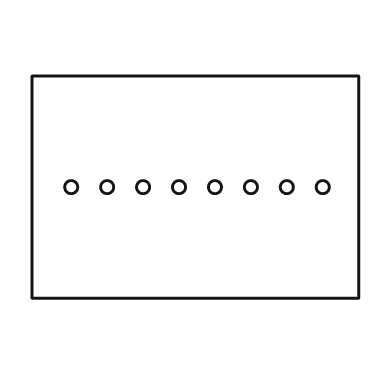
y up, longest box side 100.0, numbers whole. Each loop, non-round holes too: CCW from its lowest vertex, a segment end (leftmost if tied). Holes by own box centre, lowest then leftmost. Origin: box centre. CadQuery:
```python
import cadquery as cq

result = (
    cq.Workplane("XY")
    .moveTo(-50.0, -34.0)
    .lineTo(50.0, -34.0)
    .lineTo(50.0, 34.0)
    .lineTo(-50.0, 34.0)
    .close()
    .moveTo(-38.0, 0.0)
    .circle(2.0)
    .moveTo(-27.0, 0.0)
    .circle(2.0)
    .moveTo(-16.0, 0.0)
    .circle(2.0)
    .moveTo(-5.0, 0.0)
    .circle(2.0)
    .moveTo(6.0, 0.0)
    .circle(2.0)
    .moveTo(17.0, 0.0)
    .circle(2.0)
    .moveTo(28.0, 0.0)
    .circle(2.0)
    .moveTo(39.0, 0.0)
    .circle(2.0)
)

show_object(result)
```